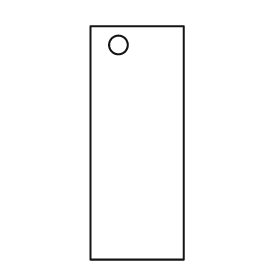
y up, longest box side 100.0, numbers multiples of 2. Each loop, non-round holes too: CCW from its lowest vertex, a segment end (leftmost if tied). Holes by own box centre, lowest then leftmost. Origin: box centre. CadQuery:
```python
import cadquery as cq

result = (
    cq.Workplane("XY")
    .moveTo(-20.0, -50.0)
    .lineTo(20.0, -50.0)
    .lineTo(20.0, 50.0)
    .lineTo(-20.0, 50.0)
    .close()
    .moveTo(-8.0, 42.0)
    .circle(4.0)
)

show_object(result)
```